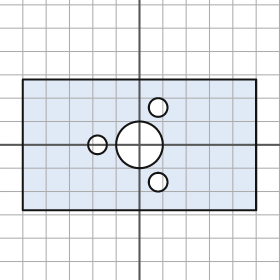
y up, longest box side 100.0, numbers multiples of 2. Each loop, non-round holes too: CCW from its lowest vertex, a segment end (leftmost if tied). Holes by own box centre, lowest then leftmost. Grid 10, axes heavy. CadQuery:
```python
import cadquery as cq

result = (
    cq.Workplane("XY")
    .moveTo(-50.0, -28.0)
    .lineTo(50.0, -28.0)
    .lineTo(50.0, 28.0)
    .lineTo(-50.0, 28.0)
    .close()
    .moveTo(8.0, -16.0)
    .circle(4.0)
    .moveTo(-18.0, 0.0)
    .circle(4.0)
    .moveTo(0.0, 0.0)
    .circle(10.0)
    .moveTo(8.0, 16.0)
    .circle(4.0)
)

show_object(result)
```